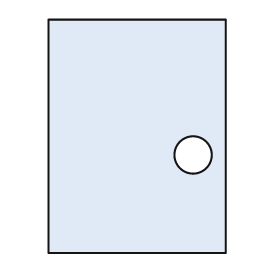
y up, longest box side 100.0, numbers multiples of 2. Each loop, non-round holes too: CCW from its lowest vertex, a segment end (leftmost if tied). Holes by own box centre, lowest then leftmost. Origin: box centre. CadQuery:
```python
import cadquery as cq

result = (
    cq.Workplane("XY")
    .moveTo(-38.0, -50.0)
    .lineTo(38.0, -50.0)
    .lineTo(38.0, 50.0)
    .lineTo(-38.0, 50.0)
    .close()
    .moveTo(24.0, -8.0)
    .circle(8.0)
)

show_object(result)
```